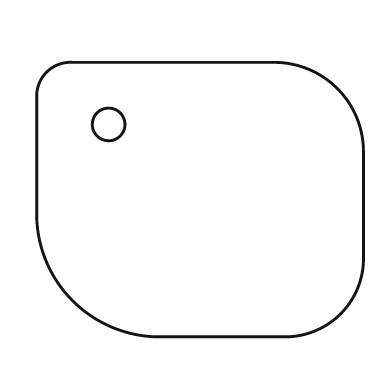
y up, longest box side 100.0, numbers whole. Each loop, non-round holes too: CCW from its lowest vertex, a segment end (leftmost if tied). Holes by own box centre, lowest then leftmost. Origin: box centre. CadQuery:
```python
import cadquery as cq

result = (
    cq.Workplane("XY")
    .moveTo(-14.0, -42.0)
    .lineTo(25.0, -42.0)
    .threePointArc((43.0, -35.0), (50.0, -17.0))
    .lineTo(50.0, 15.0)
    .threePointArc((42.0, 34.0), (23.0, 42.0))
    .lineTo(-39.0, 42.0)
    .threePointArc((-47.0, 39.0), (-50.0, 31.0))
    .lineTo(-50.0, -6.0)
    .threePointArc((-39.0, -31.0), (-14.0, -42.0))
    .close()
    .moveTo(-28.0, 23.0)
    .circle(5.0)
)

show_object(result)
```